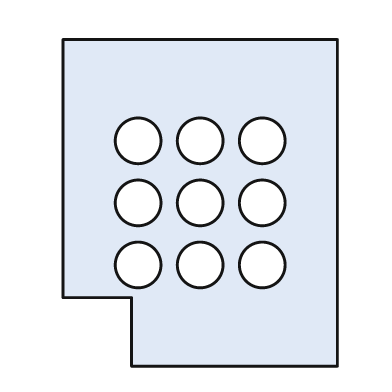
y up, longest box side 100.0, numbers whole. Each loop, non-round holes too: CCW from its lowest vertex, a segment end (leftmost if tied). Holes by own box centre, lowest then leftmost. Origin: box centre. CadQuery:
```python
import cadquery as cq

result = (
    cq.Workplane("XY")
    .moveTo(-21.0, -50.0)
    .lineTo(42.0, -50.0)
    .lineTo(42.0, 50.0)
    .lineTo(-42.0, 50.0)
    .lineTo(-42.0, -29.0)
    .lineTo(-21.0, -29.0)
    .close()
    .moveTo(-19.0, -19.0)
    .circle(7.0)
    .moveTo(0.0, -19.0)
    .circle(7.0)
    .moveTo(19.0, -19.0)
    .circle(7.0)
    .moveTo(-19.0, 0.0)
    .circle(7.0)
    .moveTo(0.0, 0.0)
    .circle(7.0)
    .moveTo(19.0, 0.0)
    .circle(7.0)
    .moveTo(-19.0, 19.0)
    .circle(7.0)
    .moveTo(0.0, 19.0)
    .circle(7.0)
    .moveTo(19.0, 19.0)
    .circle(7.0)
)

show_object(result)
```